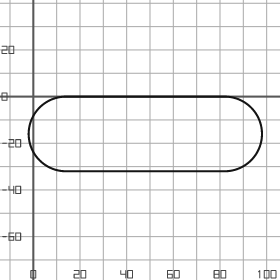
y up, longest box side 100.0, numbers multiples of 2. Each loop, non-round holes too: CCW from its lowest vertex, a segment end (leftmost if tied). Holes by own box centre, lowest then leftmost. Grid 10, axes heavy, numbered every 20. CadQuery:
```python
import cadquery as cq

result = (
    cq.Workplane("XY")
    .moveTo(14.0, -32.0)
    .lineTo(82.0, -32.0)
    .threePointArc((98.0, -16.0), (82.0, 0.0))
    .lineTo(14.0, 0.0)
    .threePointArc((-2.0, -16.0), (14.0, -32.0))
    .close()
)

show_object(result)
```